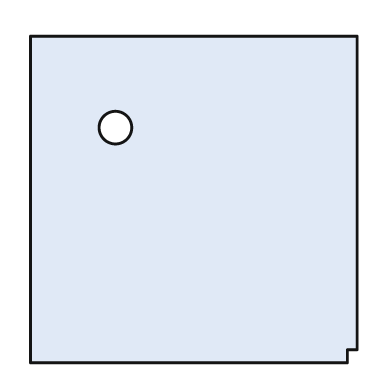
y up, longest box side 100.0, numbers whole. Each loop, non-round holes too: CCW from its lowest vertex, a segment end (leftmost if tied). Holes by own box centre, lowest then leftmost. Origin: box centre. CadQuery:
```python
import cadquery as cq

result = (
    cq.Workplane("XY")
    .moveTo(-50.0, -50.0)
    .lineTo(47.0, -50.0)
    .lineTo(47.0, -46.0)
    .lineTo(50.0, -46.0)
    .lineTo(50.0, 50.0)
    .lineTo(-50.0, 50.0)
    .close()
    .moveTo(-24.0, 22.0)
    .circle(5.0)
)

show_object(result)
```